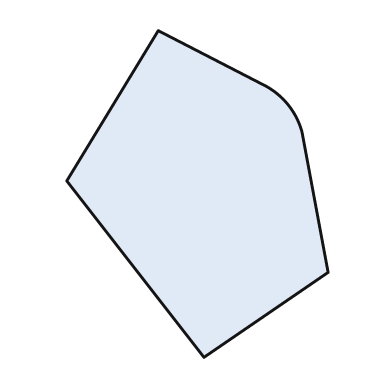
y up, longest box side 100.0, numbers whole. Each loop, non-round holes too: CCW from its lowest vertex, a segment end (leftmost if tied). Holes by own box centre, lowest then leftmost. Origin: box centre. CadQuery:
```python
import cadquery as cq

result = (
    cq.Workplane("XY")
    .moveTo(2.0, -50.0)
    .lineTo(40.0, -24.0)
    .lineTo(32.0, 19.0)
    .threePointArc((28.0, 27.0), (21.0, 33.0))
    .lineTo(-12.0, 50.0)
    .lineTo(-40.0, 4.0)
    .close()
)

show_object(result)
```